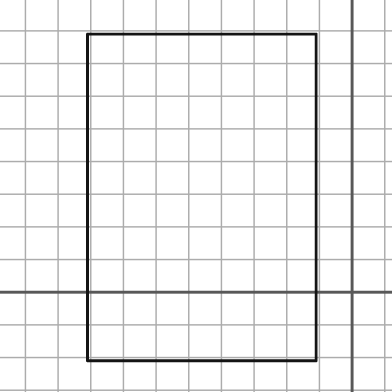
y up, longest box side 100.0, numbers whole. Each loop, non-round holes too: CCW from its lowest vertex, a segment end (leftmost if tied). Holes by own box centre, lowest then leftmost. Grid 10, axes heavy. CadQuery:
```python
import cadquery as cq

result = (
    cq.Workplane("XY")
    .moveTo(-81.0, -21.0)
    .lineTo(-11.0, -21.0)
    .lineTo(-11.0, 79.0)
    .lineTo(-81.0, 79.0)
    .close()
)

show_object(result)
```